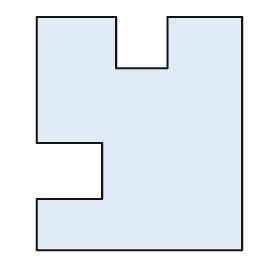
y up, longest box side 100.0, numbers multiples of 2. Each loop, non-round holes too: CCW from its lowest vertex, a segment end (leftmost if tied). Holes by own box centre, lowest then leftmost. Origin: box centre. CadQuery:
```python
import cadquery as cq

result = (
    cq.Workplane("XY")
    .moveTo(-44.0, -50.0)
    .lineTo(44.0, -50.0)
    .lineTo(44.0, 50.0)
    .lineTo(12.0, 50.0)
    .lineTo(12.0, 28.0)
    .lineTo(-10.0, 28.0)
    .lineTo(-10.0, 50.0)
    .lineTo(-44.0, 50.0)
    .lineTo(-44.0, -4.0)
    .lineTo(-16.0, -4.0)
    .lineTo(-16.0, -28.0)
    .lineTo(-44.0, -28.0)
    .close()
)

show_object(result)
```